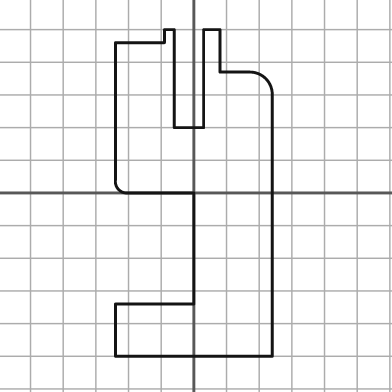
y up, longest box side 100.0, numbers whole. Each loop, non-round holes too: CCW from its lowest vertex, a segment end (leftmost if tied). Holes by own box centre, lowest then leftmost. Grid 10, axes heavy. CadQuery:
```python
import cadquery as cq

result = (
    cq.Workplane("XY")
    .moveTo(-24.0, -50.0)
    .lineTo(24.0, -50.0)
    .lineTo(24.0, 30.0)
    .threePointArc((22.0, 35.0), (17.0, 37.0))
    .lineTo(8.0, 37.0)
    .lineTo(8.0, 50.0)
    .lineTo(3.0, 50.0)
    .lineTo(3.0, 20.0)
    .lineTo(-6.0, 20.0)
    .lineTo(-6.0, 50.0)
    .lineTo(-9.0, 50.0)
    .lineTo(-9.0, 46.0)
    .lineTo(-24.0, 46.0)
    .lineTo(-24.0, 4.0)
    .threePointArc((-23.0, 1.0), (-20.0, 0.0))
    .lineTo(0.0, 0.0)
    .lineTo(0.0, -34.0)
    .lineTo(-24.0, -34.0)
    .close()
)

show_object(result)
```